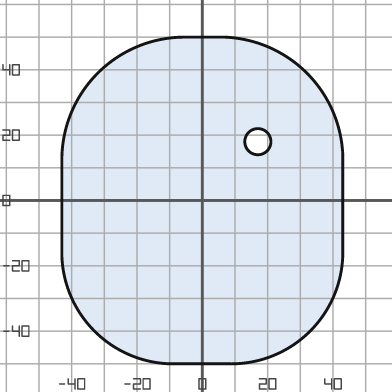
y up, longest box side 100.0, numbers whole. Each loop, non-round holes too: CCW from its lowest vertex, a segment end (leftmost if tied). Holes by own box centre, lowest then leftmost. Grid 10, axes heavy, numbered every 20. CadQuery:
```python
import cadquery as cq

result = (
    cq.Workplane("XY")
    .moveTo(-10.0, -50.0)
    .lineTo(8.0, -50.0)
    .threePointArc((33.0, -40.0), (43.0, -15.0))
    .lineTo(43.0, 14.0)
    .threePointArc((32.0, 39.0), (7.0, 50.0))
    .lineTo(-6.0, 50.0)
    .threePointArc((-32.0, 39.0), (-43.0, 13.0))
    .lineTo(-43.0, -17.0)
    .threePointArc((-33.0, -40.0), (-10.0, -50.0))
    .close()
    .moveTo(17.0, 18.0)
    .circle(4.0)
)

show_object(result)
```